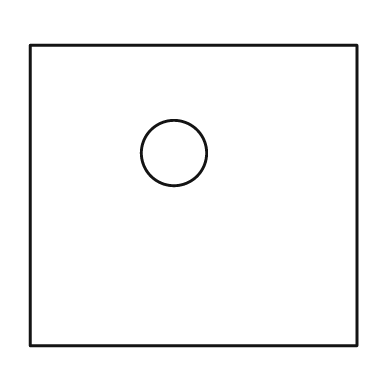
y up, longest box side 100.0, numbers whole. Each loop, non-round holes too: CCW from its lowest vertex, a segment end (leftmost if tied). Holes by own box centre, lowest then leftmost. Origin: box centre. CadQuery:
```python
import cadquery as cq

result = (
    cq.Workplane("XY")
    .moveTo(-50.0, -46.0)
    .lineTo(50.0, -46.0)
    .lineTo(50.0, 46.0)
    .lineTo(-50.0, 46.0)
    .close()
    .moveTo(-6.0, 13.0)
    .circle(10.0)
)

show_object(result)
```